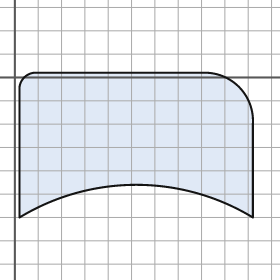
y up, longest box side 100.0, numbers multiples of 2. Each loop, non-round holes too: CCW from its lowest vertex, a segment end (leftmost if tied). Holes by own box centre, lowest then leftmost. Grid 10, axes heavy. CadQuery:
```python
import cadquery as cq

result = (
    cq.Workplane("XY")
    .moveTo(2.0, -60.0)
    .threePointArc((52.0, -46.0), (102.0, -60.0))
    .lineTo(102.0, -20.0)
    .threePointArc((96.0, -4.0), (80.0, 2.0))
    .lineTo(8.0, 2.0)
    .threePointArc((4.0, 0.0), (2.0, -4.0))
    .close()
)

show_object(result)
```